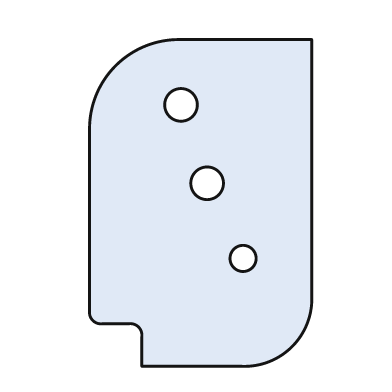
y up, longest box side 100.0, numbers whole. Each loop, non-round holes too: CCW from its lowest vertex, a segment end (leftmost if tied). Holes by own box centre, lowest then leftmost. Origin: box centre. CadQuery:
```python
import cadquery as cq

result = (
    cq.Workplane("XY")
    .moveTo(-18.0, -50.0)
    .lineTo(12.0, -50.0)
    .threePointArc((28.0, -44.0), (34.0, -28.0))
    .lineTo(34.0, 50.0)
    .lineTo(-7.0, 50.0)
    .threePointArc((-26.0, 42.0), (-34.0, 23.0))
    .lineTo(-34.0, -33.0)
    .threePointArc((-33.0, -36.0), (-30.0, -37.0))
    .lineTo(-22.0, -37.0)
    .threePointArc((-19.0, -38.0), (-18.0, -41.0))
    .close()
    .moveTo(13.0, -17.0)
    .circle(4.0)
    .moveTo(2.0, 6.0)
    .circle(5.0)
    .moveTo(-6.0, 30.0)
    .circle(5.0)
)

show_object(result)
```